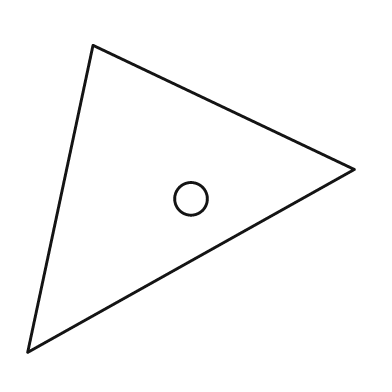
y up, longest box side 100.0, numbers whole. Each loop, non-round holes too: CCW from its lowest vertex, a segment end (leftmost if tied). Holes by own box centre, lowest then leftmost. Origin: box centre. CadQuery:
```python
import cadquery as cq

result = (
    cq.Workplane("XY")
    .moveTo(-50.0, -47.0)
    .lineTo(50.0, 9.0)
    .lineTo(-30.0, 47.0)
    .close()
    .moveTo(0.0, 0.0)
    .circle(5.0)
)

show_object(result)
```